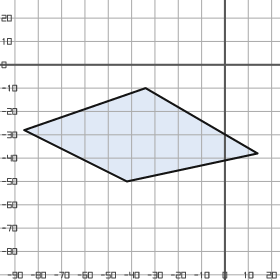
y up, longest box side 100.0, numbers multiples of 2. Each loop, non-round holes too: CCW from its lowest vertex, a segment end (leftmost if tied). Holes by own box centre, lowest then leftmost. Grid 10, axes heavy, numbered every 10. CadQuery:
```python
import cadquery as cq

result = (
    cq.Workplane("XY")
    .moveTo(-42.0, -50.0)
    .lineTo(14.0, -38.0)
    .lineTo(-34.0, -10.0)
    .lineTo(-86.0, -28.0)
    .close()
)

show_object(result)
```